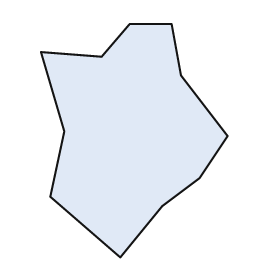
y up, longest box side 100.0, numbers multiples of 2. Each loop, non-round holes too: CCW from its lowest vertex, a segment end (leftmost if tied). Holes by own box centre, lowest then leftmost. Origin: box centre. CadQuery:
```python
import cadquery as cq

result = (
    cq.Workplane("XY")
    .moveTo(-6.0, -50.0)
    .lineTo(12.0, -28.0)
    .lineTo(28.0, -16.0)
    .lineTo(40.0, 2.0)
    .lineTo(20.0, 28.0)
    .lineTo(16.0, 50.0)
    .lineTo(-2.0, 50.0)
    .lineTo(-14.0, 36.0)
    .lineTo(-40.0, 38.0)
    .lineTo(-30.0, 4.0)
    .lineTo(-36.0, -24.0)
    .close()
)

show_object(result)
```